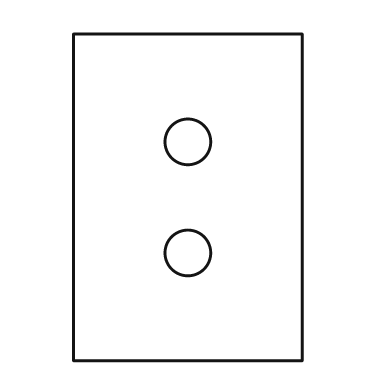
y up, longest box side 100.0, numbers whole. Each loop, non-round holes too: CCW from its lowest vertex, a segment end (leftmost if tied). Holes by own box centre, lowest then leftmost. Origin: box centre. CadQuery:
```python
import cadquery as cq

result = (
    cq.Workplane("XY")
    .moveTo(-35.0, -50.0)
    .lineTo(35.0, -50.0)
    .lineTo(35.0, 50.0)
    .lineTo(-35.0, 50.0)
    .close()
    .moveTo(0.0, -17.0)
    .circle(7.0)
    .moveTo(0.0, 17.0)
    .circle(7.0)
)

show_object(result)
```